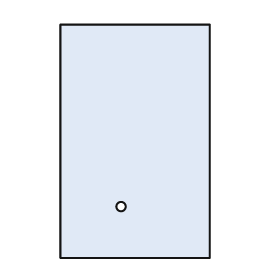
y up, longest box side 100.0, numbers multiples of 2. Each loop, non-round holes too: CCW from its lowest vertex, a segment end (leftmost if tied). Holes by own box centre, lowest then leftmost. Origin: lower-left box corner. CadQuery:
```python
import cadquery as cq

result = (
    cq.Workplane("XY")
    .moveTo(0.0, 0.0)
    .lineTo(64.0, 0.0)
    .lineTo(64.0, 100.0)
    .lineTo(0.0, 100.0)
    .close()
    .moveTo(26.0, 22.0)
    .circle(2.0)
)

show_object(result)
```